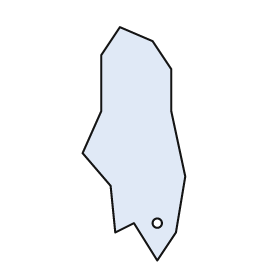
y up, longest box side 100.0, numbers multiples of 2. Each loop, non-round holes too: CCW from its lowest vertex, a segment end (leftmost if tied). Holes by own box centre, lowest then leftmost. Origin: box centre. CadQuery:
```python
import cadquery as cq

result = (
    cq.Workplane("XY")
    .moveTo(10.0, -50.0)
    .lineTo(18.0, -38.0)
    .lineTo(22.0, -14.0)
    .lineTo(16.0, 14.0)
    .lineTo(16.0, 32.0)
    .lineTo(8.0, 44.0)
    .lineTo(-6.0, 50.0)
    .lineTo(-14.0, 38.0)
    .lineTo(-14.0, 14.0)
    .lineTo(-22.0, -4.0)
    .lineTo(-10.0, -18.0)
    .lineTo(-8.0, -38.0)
    .lineTo(0.0, -34.0)
    .close()
    .moveTo(10.0, -34.0)
    .circle(2.0)
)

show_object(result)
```